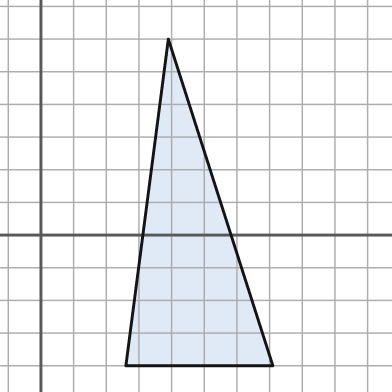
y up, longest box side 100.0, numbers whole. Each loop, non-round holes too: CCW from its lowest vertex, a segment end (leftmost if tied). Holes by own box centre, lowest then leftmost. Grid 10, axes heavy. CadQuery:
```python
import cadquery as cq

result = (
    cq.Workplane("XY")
    .moveTo(26.0, -40.0)
    .lineTo(71.0, -40.0)
    .lineTo(39.0, 60.0)
    .close()
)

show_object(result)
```